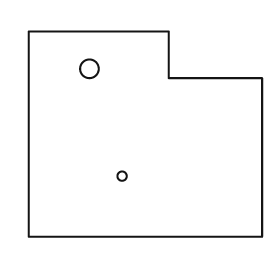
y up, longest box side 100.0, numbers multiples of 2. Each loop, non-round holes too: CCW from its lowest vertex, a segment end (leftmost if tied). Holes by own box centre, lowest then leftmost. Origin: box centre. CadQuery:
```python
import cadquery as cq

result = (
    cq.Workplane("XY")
    .moveTo(-50.0, -44.0)
    .lineTo(50.0, -44.0)
    .lineTo(50.0, 24.0)
    .lineTo(10.0, 24.0)
    .lineTo(10.0, 44.0)
    .lineTo(-50.0, 44.0)
    .close()
    .moveTo(-10.0, -18.0)
    .circle(2.0)
    .moveTo(-24.0, 28.0)
    .circle(4.0)
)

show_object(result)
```